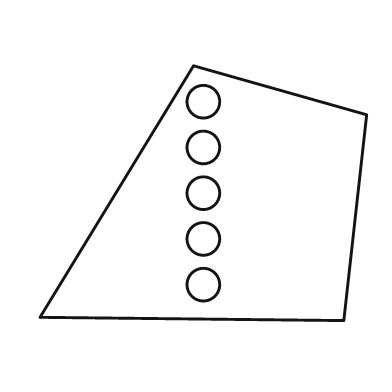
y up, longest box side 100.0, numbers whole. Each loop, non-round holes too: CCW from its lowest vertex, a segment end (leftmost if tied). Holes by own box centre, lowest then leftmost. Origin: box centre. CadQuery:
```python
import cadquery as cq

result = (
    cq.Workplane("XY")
    .moveTo(43.0, -39.0)
    .lineTo(50.0, 24.0)
    .lineTo(-3.0, 39.0)
    .lineTo(-50.0, -38.0)
    .close()
    .moveTo(0.0, -28.0)
    .circle(5.0)
    .moveTo(0.0, -14.0)
    .circle(5.0)
    .moveTo(0.0, 0.0)
    .circle(5.0)
    .moveTo(0.0, 14.0)
    .circle(5.0)
    .moveTo(0.0, 28.0)
    .circle(5.0)
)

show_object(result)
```